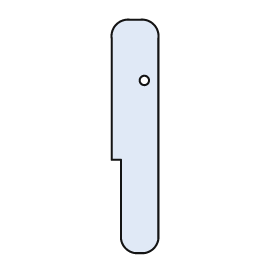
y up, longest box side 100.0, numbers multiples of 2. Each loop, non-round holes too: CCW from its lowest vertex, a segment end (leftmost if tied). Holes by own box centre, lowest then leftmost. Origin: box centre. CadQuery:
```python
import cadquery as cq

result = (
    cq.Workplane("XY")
    .moveTo(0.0, -50.0)
    .lineTo(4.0, -50.0)
    .threePointArc((8.0, -48.0), (10.0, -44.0))
    .lineTo(10.0, 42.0)
    .threePointArc((8.0, 48.0), (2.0, 50.0))
    .lineTo(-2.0, 50.0)
    .threePointArc((-8.0, 48.0), (-10.0, 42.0))
    .lineTo(-10.0, -10.0)
    .lineTo(-6.0, -10.0)
    .lineTo(-6.0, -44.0)
    .threePointArc((-4.0, -48.0), (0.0, -50.0))
    .close()
    .moveTo(4.0, 24.0)
    .circle(2.0)
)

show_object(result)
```